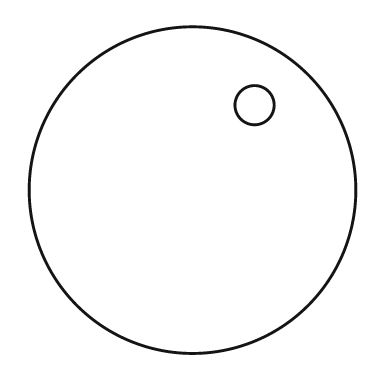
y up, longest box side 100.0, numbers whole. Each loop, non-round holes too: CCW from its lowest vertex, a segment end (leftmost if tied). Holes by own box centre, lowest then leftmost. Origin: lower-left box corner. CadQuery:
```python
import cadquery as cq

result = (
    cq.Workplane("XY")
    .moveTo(50.0, 50.0)
    .circle(50.0)
    .moveTo(69.0, 76.0)
    .circle(6.0)
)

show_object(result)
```